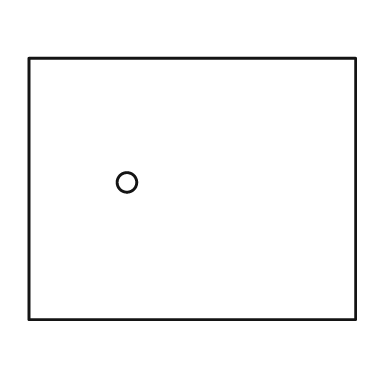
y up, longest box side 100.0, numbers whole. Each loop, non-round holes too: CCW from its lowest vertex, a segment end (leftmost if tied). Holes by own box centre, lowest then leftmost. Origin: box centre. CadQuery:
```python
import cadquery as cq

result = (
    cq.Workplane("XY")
    .moveTo(-50.0, -40.0)
    .lineTo(50.0, -40.0)
    .lineTo(50.0, 40.0)
    .lineTo(-50.0, 40.0)
    .close()
    .moveTo(-20.0, 2.0)
    .circle(3.0)
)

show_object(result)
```